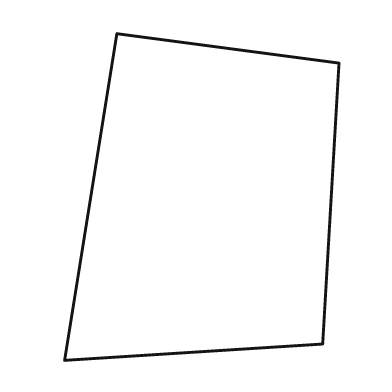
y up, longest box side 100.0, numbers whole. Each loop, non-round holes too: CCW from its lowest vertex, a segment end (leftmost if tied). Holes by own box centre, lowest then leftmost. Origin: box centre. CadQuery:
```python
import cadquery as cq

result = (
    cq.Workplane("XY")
    .moveTo(-42.0, -50.0)
    .lineTo(37.0, -45.0)
    .lineTo(42.0, 41.0)
    .lineTo(-26.0, 50.0)
    .close()
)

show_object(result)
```